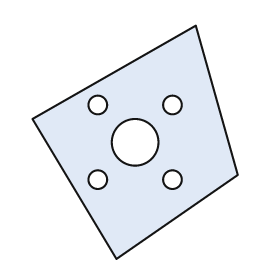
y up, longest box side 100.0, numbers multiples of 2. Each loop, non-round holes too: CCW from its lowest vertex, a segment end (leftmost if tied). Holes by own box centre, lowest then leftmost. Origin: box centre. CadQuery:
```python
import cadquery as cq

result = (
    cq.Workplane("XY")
    .moveTo(-8.0, -50.0)
    .lineTo(44.0, -14.0)
    .lineTo(26.0, 50.0)
    .lineTo(-44.0, 10.0)
    .close()
    .moveTo(-16.0, -16.0)
    .circle(4.0)
    .moveTo(16.0, -16.0)
    .circle(4.0)
    .moveTo(0.0, 0.0)
    .circle(10.0)
    .moveTo(-16.0, 16.0)
    .circle(4.0)
    .moveTo(16.0, 16.0)
    .circle(4.0)
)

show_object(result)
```